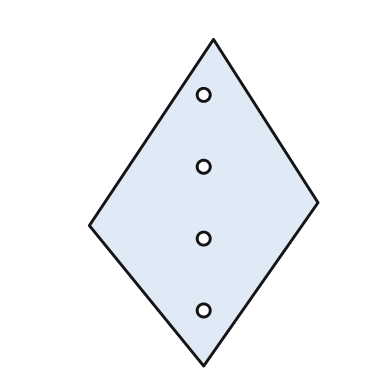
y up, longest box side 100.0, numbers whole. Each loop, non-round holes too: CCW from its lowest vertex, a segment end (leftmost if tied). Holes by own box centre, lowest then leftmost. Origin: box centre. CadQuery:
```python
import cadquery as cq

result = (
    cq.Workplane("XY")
    .moveTo(0.0, -50.0)
    .lineTo(35.0, 0.0)
    .lineTo(3.0, 50.0)
    .lineTo(-35.0, -7.0)
    .close()
    .moveTo(0.0, -33.0)
    .circle(2.0)
    .moveTo(0.0, -11.0)
    .circle(2.0)
    .moveTo(0.0, 11.0)
    .circle(2.0)
    .moveTo(0.0, 33.0)
    .circle(2.0)
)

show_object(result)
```